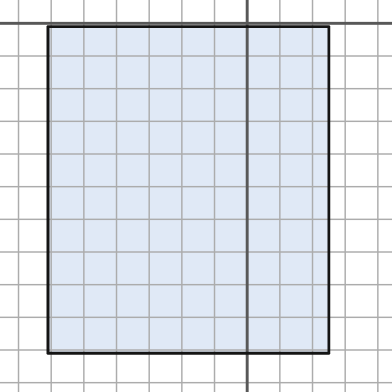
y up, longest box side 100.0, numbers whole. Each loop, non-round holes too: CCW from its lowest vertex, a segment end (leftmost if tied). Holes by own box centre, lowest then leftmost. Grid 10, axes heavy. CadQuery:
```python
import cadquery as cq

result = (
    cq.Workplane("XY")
    .moveTo(-61.0, -101.0)
    .lineTo(25.0, -101.0)
    .lineTo(25.0, -1.0)
    .lineTo(-61.0, -1.0)
    .close()
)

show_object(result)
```